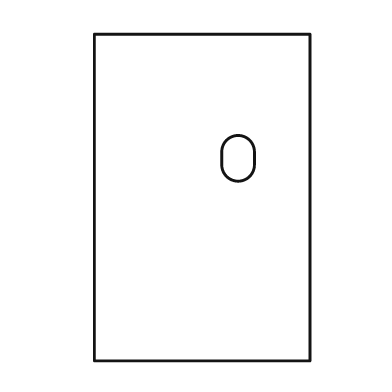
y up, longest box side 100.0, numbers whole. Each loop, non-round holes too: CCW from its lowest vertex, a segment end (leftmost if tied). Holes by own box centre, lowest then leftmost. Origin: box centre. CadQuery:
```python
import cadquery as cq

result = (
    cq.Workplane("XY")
    .moveTo(-33.0, -50.0)
    .lineTo(33.0, -50.0)
    .lineTo(33.0, 50.0)
    .lineTo(-33.0, 50.0)
    .close()
    .moveTo(6.0, 10.0)
    .threePointArc((11.0, 5.0), (16.0, 10.0))
    .lineTo(16.0, 14.0)
    .threePointArc((11.0, 19.0), (6.0, 14.0))
    .close()
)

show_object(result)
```